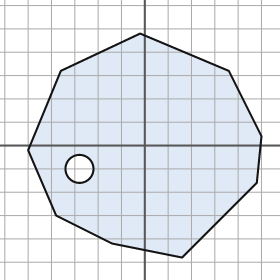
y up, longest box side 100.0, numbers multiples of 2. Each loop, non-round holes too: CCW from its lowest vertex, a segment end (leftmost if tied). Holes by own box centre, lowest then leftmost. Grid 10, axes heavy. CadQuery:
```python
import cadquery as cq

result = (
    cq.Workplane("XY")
    .moveTo(16.0, -48.0)
    .lineTo(48.0, -16.0)
    .lineTo(50.0, 4.0)
    .lineTo(36.0, 32.0)
    .lineTo(-2.0, 48.0)
    .lineTo(-36.0, 32.0)
    .lineTo(-50.0, -2.0)
    .lineTo(-38.0, -30.0)
    .lineTo(-14.0, -42.0)
    .close()
    .moveTo(-28.0, -10.0)
    .circle(6.0)
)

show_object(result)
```